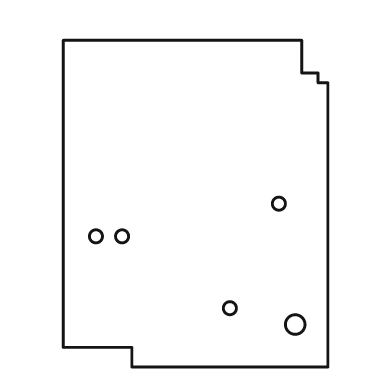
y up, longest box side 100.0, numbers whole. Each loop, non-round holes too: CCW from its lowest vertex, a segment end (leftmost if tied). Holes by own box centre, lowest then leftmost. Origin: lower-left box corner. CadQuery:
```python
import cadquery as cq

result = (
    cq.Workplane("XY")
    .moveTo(21.0, 0.0)
    .lineTo(81.0, 0.0)
    .lineTo(81.0, 87.0)
    .lineTo(78.0, 87.0)
    .lineTo(78.0, 90.0)
    .lineTo(73.0, 90.0)
    .lineTo(73.0, 100.0)
    .lineTo(0.0, 100.0)
    .lineTo(0.0, 6.0)
    .lineTo(21.0, 6.0)
    .close()
    .moveTo(71.0, 13.0)
    .circle(3.0)
    .moveTo(51.0, 18.0)
    .circle(2.0)
    .moveTo(10.0, 40.0)
    .circle(2.0)
    .moveTo(18.0, 40.0)
    .circle(2.0)
    .moveTo(66.0, 50.0)
    .circle(2.0)
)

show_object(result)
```